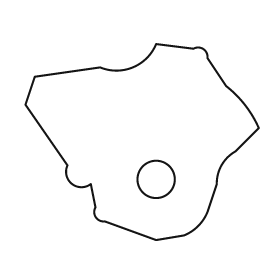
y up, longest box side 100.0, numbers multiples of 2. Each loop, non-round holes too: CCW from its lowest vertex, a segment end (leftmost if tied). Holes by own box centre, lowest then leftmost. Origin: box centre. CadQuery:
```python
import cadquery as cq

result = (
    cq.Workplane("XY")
    .moveTo(6.0, -42.0)
    .lineTo(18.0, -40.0)
    .threePointArc((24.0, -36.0), (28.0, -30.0))
    .lineTo(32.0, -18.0)
    .threePointArc((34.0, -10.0), (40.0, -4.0))
    .lineTo(50.0, 6.0)
    .threePointArc((44.0, 16.0), (36.0, 24.0))
    .lineTo(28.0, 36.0)
    .threePointArc((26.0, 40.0), (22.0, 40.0))
    .lineTo(6.0, 42.0)
    .threePointArc((-4.0, 32.0), (-18.0, 32.0))
    .lineTo(-46.0, 28.0)
    .lineTo(-50.0, 16.0)
    .lineTo(-32.0, -10.0)
    .threePointArc((-30.0, -18.0), (-22.0, -18.0))
    .lineTo(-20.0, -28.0)
    .threePointArc((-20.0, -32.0), (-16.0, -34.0))
    .close()
    .moveTo(6.0, -16.0)
    .circle(8.0)
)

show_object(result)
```